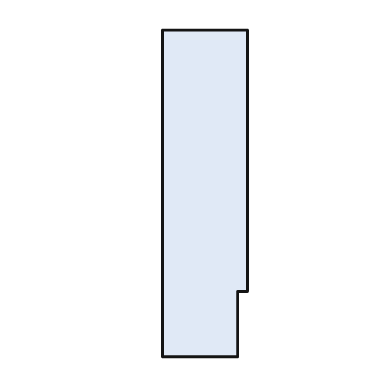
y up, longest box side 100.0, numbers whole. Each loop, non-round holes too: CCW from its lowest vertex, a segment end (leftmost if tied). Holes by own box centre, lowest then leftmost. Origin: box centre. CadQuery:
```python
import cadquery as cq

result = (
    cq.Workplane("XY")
    .moveTo(-13.0, -50.0)
    .lineTo(10.0, -50.0)
    .lineTo(10.0, -30.0)
    .lineTo(13.0, -30.0)
    .lineTo(13.0, 50.0)
    .lineTo(-13.0, 50.0)
    .close()
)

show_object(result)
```